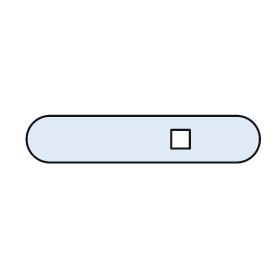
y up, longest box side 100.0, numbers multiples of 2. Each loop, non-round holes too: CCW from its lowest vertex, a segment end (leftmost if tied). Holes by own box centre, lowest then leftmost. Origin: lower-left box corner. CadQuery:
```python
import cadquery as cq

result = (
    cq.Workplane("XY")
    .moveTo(10.0, 0.0)
    .lineTo(90.0, 0.0)
    .threePointArc((100.0, 10.0), (90.0, 20.0))
    .lineTo(10.0, 20.0)
    .threePointArc((0.0, 10.0), (10.0, 0.0))
    .close()
    .moveTo(62.0, 6.0)
    .lineTo(70.0, 6.0)
    .lineTo(70.0, 14.0)
    .lineTo(62.0, 14.0)
    .close()
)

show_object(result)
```